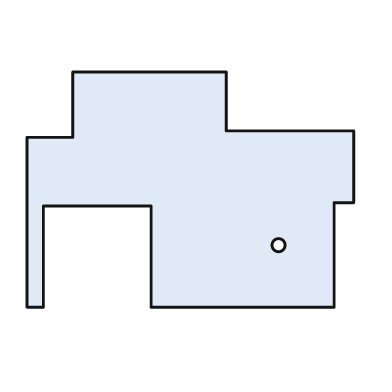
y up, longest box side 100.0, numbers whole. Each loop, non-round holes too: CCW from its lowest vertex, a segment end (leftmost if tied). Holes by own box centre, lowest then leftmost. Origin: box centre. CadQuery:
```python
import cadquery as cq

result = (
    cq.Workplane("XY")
    .moveTo(-50.0, -36.0)
    .lineTo(-45.0, -36.0)
    .lineTo(-45.0, -5.0)
    .lineTo(-12.0, -5.0)
    .lineTo(-12.0, -36.0)
    .lineTo(44.0, -36.0)
    .lineTo(44.0, -4.0)
    .lineTo(50.0, -4.0)
    .lineTo(50.0, 18.0)
    .lineTo(11.0, 18.0)
    .lineTo(11.0, 36.0)
    .lineTo(-36.0, 36.0)
    .lineTo(-36.0, 16.0)
    .lineTo(-50.0, 16.0)
    .close()
    .moveTo(27.0, -17.0)
    .circle(2.0)
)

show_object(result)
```